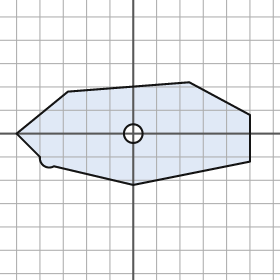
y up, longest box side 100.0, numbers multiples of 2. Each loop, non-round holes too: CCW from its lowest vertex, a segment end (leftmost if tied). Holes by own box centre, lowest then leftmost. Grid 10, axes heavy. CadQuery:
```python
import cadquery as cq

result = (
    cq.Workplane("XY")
    .moveTo(0.0, -22.0)
    .lineTo(50.0, -12.0)
    .lineTo(50.0, 8.0)
    .lineTo(24.0, 22.0)
    .lineTo(-28.0, 18.0)
    .lineTo(-50.0, 0.0)
    .lineTo(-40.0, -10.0)
    .threePointArc((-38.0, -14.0), (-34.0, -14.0))
    .close()
    .moveTo(0.0, 0.0)
    .circle(4.0)
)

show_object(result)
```